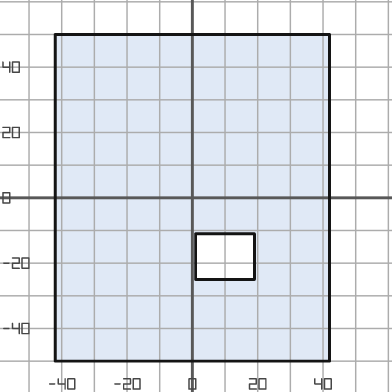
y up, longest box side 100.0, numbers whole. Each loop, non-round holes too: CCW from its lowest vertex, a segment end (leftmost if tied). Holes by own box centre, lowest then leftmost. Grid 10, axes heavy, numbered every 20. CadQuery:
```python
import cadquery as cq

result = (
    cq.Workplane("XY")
    .moveTo(-42.0, -50.0)
    .lineTo(42.0, -50.0)
    .lineTo(42.0, 50.0)
    .lineTo(-42.0, 50.0)
    .close()
    .moveTo(1.0, -25.0)
    .lineTo(19.0, -25.0)
    .lineTo(19.0, -11.0)
    .lineTo(1.0, -11.0)
    .close()
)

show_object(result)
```